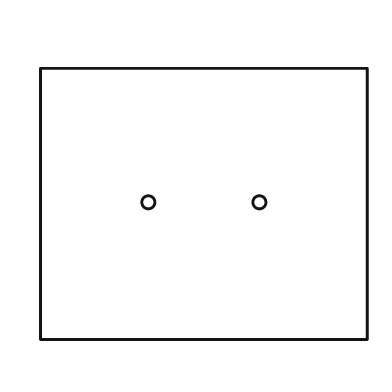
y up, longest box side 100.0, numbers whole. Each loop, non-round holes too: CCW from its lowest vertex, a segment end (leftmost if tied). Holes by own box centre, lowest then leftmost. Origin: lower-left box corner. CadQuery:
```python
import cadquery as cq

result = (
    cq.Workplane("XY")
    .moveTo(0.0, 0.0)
    .lineTo(100.0, 0.0)
    .lineTo(100.0, 83.0)
    .lineTo(0.0, 83.0)
    .close()
    .moveTo(33.0, 42.0)
    .circle(2.0)
    .moveTo(67.0, 42.0)
    .circle(2.0)
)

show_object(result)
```